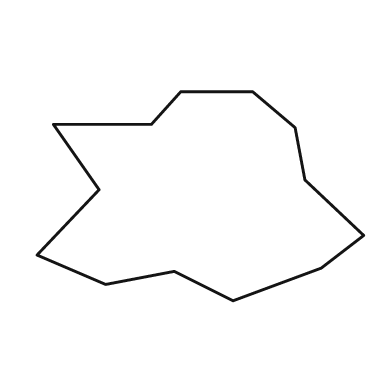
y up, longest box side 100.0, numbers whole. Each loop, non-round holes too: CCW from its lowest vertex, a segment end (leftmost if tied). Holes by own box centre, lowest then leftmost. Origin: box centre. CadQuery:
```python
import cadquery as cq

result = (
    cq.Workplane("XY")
    .moveTo(10.0, -32.0)
    .lineTo(37.0, -22.0)
    .lineTo(50.0, -12.0)
    .lineTo(32.0, 5.0)
    .lineTo(29.0, 21.0)
    .lineTo(16.0, 32.0)
    .lineTo(-6.0, 32.0)
    .lineTo(-15.0, 22.0)
    .lineTo(-45.0, 22.0)
    .lineTo(-31.0, 2.0)
    .lineTo(-50.0, -18.0)
    .lineTo(-29.0, -27.0)
    .lineTo(-8.0, -23.0)
    .close()
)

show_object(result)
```